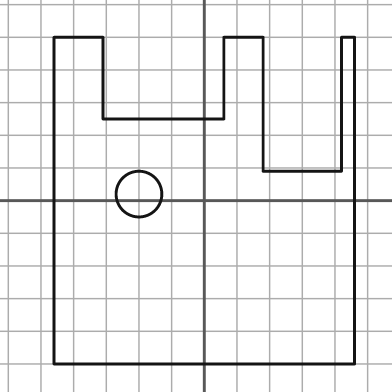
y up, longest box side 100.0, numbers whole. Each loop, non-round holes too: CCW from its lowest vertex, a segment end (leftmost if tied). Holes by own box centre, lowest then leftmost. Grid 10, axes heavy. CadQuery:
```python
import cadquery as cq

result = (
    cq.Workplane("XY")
    .moveTo(-46.0, -50.0)
    .lineTo(46.0, -50.0)
    .lineTo(46.0, 50.0)
    .lineTo(42.0, 50.0)
    .lineTo(42.0, 9.0)
    .lineTo(18.0, 9.0)
    .lineTo(18.0, 50.0)
    .lineTo(6.0, 50.0)
    .lineTo(6.0, 25.0)
    .lineTo(-31.0, 25.0)
    .lineTo(-31.0, 50.0)
    .lineTo(-46.0, 50.0)
    .close()
    .moveTo(-20.0, 2.0)
    .circle(7.0)
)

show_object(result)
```